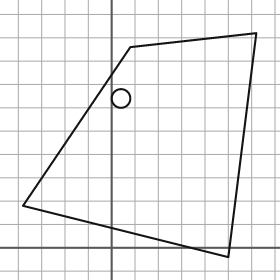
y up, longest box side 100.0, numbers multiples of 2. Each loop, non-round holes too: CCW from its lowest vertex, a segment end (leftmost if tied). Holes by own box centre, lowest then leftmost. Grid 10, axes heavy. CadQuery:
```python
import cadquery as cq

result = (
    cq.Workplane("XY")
    .moveTo(50.0, -4.0)
    .lineTo(62.0, 92.0)
    .lineTo(8.0, 86.0)
    .lineTo(-38.0, 18.0)
    .close()
    .moveTo(4.0, 64.0)
    .circle(4.0)
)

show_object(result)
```